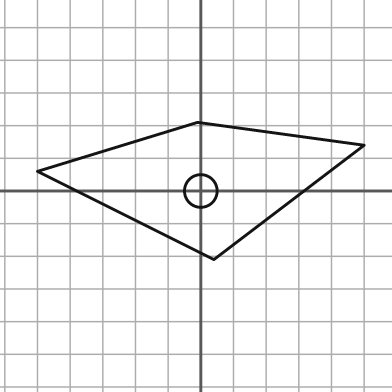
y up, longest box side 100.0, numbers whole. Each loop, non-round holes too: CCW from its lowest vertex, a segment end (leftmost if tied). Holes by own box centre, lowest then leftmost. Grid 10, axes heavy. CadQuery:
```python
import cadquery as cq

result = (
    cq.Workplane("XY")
    .moveTo(4.0, -21.0)
    .lineTo(50.0, 14.0)
    .lineTo(-1.0, 21.0)
    .lineTo(-50.0, 6.0)
    .close()
    .moveTo(0.0, 0.0)
    .circle(5.0)
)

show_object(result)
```